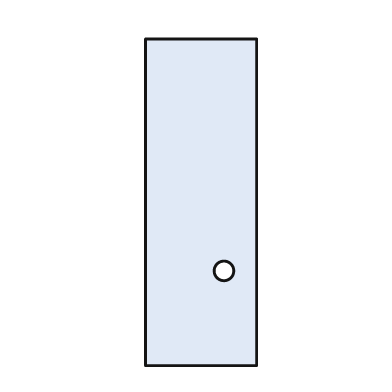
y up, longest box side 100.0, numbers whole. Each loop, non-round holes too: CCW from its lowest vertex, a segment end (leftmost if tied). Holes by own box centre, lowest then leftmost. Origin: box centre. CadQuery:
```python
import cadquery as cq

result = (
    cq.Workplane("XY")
    .moveTo(-17.0, -50.0)
    .lineTo(17.0, -50.0)
    .lineTo(17.0, 50.0)
    .lineTo(-17.0, 50.0)
    .close()
    .moveTo(7.0, -21.0)
    .circle(3.0)
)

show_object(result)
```